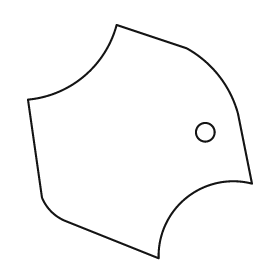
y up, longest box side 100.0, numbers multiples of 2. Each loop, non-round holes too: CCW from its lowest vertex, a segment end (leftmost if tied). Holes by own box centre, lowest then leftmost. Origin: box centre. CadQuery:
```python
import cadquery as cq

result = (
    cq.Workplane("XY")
    .moveTo(8.0, -50.0)
    .threePointArc((20.0, -24.0), (48.0, -18.0))
    .lineTo(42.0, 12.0)
    .threePointArc((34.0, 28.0), (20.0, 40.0))
    .lineTo(-10.0, 50.0)
    .threePointArc((-24.0, 28.0), (-48.0, 18.0))
    .lineTo(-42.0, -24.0)
    .threePointArc((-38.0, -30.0), (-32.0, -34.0))
    .close()
    .moveTo(28.0, 4.0)
    .circle(4.0)
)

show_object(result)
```